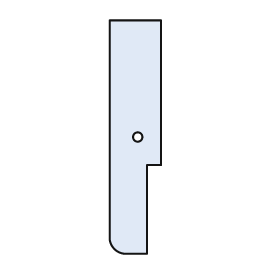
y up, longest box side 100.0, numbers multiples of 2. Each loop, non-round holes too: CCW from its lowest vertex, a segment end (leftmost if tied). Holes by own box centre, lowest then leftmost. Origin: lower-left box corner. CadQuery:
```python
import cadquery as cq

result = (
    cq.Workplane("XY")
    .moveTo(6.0, 0.0)
    .lineTo(16.0, 0.0)
    .lineTo(16.0, 38.0)
    .lineTo(22.0, 38.0)
    .lineTo(22.0, 100.0)
    .lineTo(0.0, 100.0)
    .lineTo(0.0, 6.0)
    .threePointArc((2.0, 2.0), (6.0, 0.0))
    .close()
    .moveTo(12.0, 50.0)
    .circle(2.0)
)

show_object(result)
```